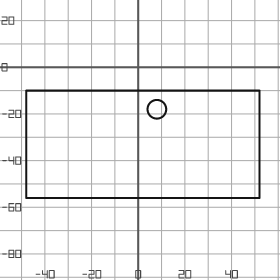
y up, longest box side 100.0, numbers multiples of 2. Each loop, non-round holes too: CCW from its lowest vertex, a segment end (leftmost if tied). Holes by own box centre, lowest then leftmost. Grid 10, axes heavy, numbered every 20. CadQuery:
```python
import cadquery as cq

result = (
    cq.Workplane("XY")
    .moveTo(-48.0, -56.0)
    .lineTo(52.0, -56.0)
    .lineTo(52.0, -10.0)
    .lineTo(-48.0, -10.0)
    .close()
    .moveTo(8.0, -18.0)
    .circle(4.0)
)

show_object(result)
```